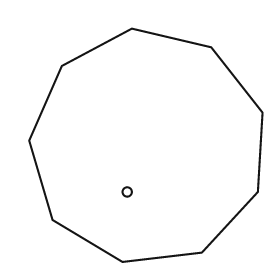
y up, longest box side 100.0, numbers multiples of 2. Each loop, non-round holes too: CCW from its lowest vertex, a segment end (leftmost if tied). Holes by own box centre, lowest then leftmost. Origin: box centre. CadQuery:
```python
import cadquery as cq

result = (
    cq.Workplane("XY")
    .moveTo(-10.0, -50.0)
    .lineTo(24.0, -46.0)
    .lineTo(48.0, -20.0)
    .lineTo(50.0, 14.0)
    .lineTo(28.0, 42.0)
    .lineTo(-6.0, 50.0)
    .lineTo(-36.0, 34.0)
    .lineTo(-50.0, 2.0)
    .lineTo(-40.0, -32.0)
    .close()
    .moveTo(-8.0, -20.0)
    .circle(2.0)
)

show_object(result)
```